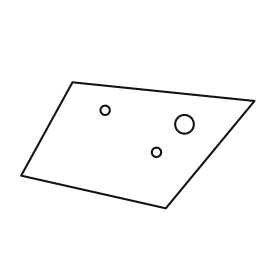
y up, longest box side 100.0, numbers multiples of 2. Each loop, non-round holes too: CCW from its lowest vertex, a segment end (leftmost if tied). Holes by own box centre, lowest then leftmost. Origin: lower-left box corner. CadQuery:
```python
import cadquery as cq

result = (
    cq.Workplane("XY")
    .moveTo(62.0, 0.0)
    .lineTo(100.0, 46.0)
    .lineTo(22.0, 54.0)
    .lineTo(0.0, 14.0)
    .close()
    .moveTo(58.0, 24.0)
    .circle(2.0)
    .moveTo(70.0, 36.0)
    .circle(4.0)
    .moveTo(36.0, 42.0)
    .circle(2.0)
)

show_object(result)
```